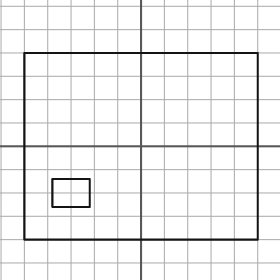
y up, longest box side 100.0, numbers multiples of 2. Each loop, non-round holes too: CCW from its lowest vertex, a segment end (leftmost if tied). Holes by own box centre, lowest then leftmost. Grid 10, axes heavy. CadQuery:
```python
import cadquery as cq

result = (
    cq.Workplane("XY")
    .moveTo(-50.0, -40.0)
    .lineTo(50.0, -40.0)
    .lineTo(50.0, 40.0)
    .lineTo(-50.0, 40.0)
    .close()
    .moveTo(-38.0, -26.0)
    .lineTo(-22.0, -26.0)
    .lineTo(-22.0, -14.0)
    .lineTo(-38.0, -14.0)
    .close()
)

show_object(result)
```